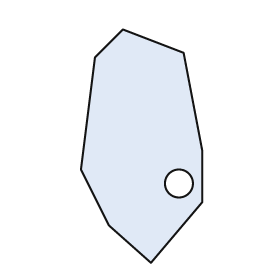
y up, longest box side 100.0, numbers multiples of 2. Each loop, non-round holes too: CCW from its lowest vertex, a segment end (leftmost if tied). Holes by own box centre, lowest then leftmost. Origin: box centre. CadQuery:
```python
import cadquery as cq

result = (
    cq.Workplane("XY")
    .moveTo(4.0, -50.0)
    .lineTo(26.0, -24.0)
    .lineTo(26.0, -2.0)
    .lineTo(18.0, 40.0)
    .lineTo(-8.0, 50.0)
    .lineTo(-20.0, 38.0)
    .lineTo(-26.0, -10.0)
    .lineTo(-14.0, -34.0)
    .close()
    .moveTo(16.0, -16.0)
    .circle(6.0)
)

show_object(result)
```